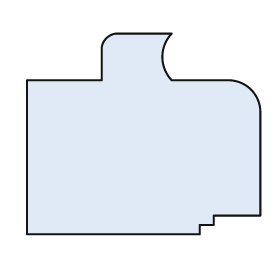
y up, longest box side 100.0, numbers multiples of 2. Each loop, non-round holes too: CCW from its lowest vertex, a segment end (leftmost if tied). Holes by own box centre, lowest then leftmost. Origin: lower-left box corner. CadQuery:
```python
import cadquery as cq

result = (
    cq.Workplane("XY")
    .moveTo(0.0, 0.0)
    .lineTo(74.0, 0.0)
    .lineTo(74.0, 4.0)
    .lineTo(80.0, 4.0)
    .lineTo(80.0, 8.0)
    .lineTo(100.0, 8.0)
    .lineTo(100.0, 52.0)
    .threePointArc((96.0, 62.0), (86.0, 66.0))
    .lineTo(62.0, 66.0)
    .threePointArc((58.0, 76.0), (62.0, 86.0))
    .lineTo(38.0, 86.0)
    .threePointArc((34.0, 84.0), (32.0, 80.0))
    .lineTo(32.0, 66.0)
    .lineTo(0.0, 66.0)
    .close()
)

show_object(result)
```